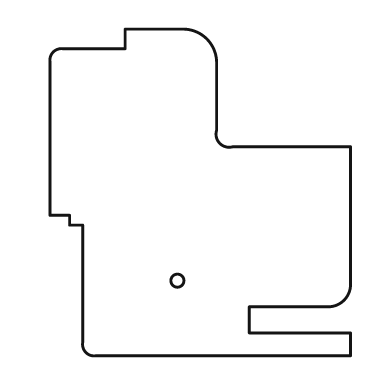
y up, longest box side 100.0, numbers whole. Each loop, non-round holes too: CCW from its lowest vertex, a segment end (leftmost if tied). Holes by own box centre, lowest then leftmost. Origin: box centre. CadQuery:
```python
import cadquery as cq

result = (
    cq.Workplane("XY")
    .moveTo(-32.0, -50.0)
    .lineTo(46.0, -50.0)
    .lineTo(46.0, -43.0)
    .lineTo(15.0, -43.0)
    .lineTo(15.0, -35.0)
    .lineTo(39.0, -35.0)
    .threePointArc((44.0, -33.0), (46.0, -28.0))
    .lineTo(46.0, 14.0)
    .lineTo(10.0, 14.0)
    .threePointArc((6.0, 15.0), (5.0, 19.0))
    .lineTo(5.0, 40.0)
    .threePointArc((2.0, 47.0), (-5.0, 50.0))
    .lineTo(-23.0, 50.0)
    .lineTo(-23.0, 44.0)
    .lineTo(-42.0, 44.0)
    .threePointArc((-45.0, 43.0), (-46.0, 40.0))
    .lineTo(-46.0, -7.0)
    .lineTo(-40.0, -7.0)
    .lineTo(-40.0, -10.0)
    .lineTo(-36.0, -10.0)
    .lineTo(-36.0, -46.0)
    .threePointArc((-35.0, -49.0), (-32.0, -50.0))
    .close()
    .moveTo(-7.0, -27.0)
    .circle(2.0)
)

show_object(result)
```